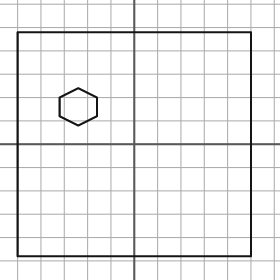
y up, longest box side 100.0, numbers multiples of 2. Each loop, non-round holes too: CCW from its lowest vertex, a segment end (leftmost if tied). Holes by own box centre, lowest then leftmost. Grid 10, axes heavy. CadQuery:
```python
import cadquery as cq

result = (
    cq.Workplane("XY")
    .moveTo(-50.0, -48.0)
    .lineTo(50.0, -48.0)
    .lineTo(50.0, 48.0)
    .lineTo(-50.0, 48.0)
    .close()
    .moveTo(-24.0, 8.0)
    .lineTo(-16.0, 12.0)
    .lineTo(-16.0, 20.0)
    .lineTo(-24.0, 24.0)
    .lineTo(-32.0, 20.0)
    .lineTo(-32.0, 12.0)
    .close()
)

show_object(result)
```